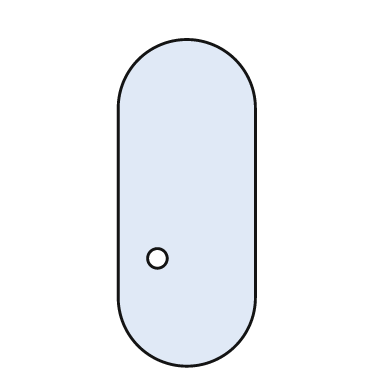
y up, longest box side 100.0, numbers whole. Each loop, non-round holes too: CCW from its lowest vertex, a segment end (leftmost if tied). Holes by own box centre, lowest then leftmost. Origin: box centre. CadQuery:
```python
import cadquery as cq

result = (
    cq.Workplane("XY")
    .moveTo(-21.0, -29.0)
    .threePointArc((0.0, -50.0), (21.0, -29.0))
    .lineTo(21.0, 29.0)
    .threePointArc((0.0, 50.0), (-21.0, 29.0))
    .close()
    .moveTo(-9.0, -17.0)
    .circle(3.0)
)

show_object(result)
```